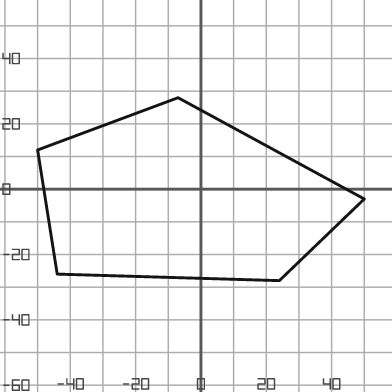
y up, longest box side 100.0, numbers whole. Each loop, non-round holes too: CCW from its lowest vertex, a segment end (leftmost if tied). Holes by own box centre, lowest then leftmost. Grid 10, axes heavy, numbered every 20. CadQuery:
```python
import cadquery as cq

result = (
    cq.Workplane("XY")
    .moveTo(24.0, -28.0)
    .lineTo(50.0, -3.0)
    .lineTo(-7.0, 28.0)
    .lineTo(-50.0, 12.0)
    .lineTo(-44.0, -26.0)
    .close()
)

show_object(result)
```